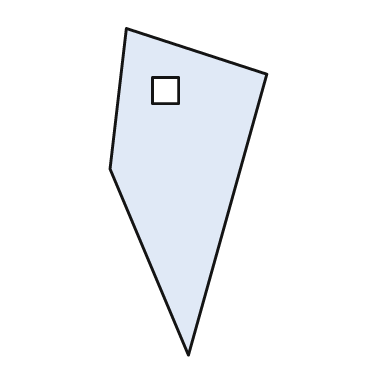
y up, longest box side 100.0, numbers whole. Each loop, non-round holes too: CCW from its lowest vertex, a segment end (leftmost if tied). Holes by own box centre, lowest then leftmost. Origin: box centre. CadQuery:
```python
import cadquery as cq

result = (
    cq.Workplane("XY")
    .moveTo(0.0, -50.0)
    .lineTo(24.0, 36.0)
    .lineTo(-19.0, 50.0)
    .lineTo(-24.0, 7.0)
    .close()
    .moveTo(-11.0, 27.0)
    .lineTo(-3.0, 27.0)
    .lineTo(-3.0, 35.0)
    .lineTo(-11.0, 35.0)
    .close()
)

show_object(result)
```